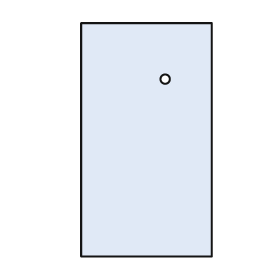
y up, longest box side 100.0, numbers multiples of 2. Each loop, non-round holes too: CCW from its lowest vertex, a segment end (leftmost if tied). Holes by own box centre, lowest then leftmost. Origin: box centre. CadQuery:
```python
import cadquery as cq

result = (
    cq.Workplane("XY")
    .moveTo(-28.0, -50.0)
    .lineTo(28.0, -50.0)
    .lineTo(28.0, 50.0)
    .lineTo(-28.0, 50.0)
    .close()
    .moveTo(8.0, 26.0)
    .circle(2.0)
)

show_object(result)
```